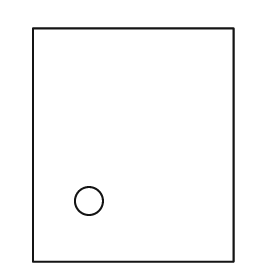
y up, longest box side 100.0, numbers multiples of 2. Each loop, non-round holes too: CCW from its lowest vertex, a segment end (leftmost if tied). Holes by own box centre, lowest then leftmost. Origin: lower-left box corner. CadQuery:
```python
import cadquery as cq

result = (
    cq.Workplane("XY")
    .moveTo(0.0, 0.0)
    .lineTo(86.0, 0.0)
    .lineTo(86.0, 100.0)
    .lineTo(0.0, 100.0)
    .close()
    .moveTo(24.0, 26.0)
    .circle(6.0)
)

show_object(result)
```